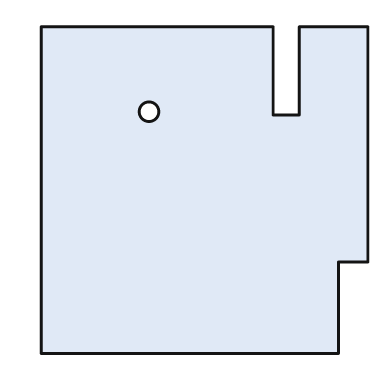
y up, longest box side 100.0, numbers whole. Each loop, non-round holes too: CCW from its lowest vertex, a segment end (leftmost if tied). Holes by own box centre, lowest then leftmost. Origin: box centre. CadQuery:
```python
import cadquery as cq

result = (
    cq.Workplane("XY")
    .moveTo(-50.0, -50.0)
    .lineTo(41.0, -50.0)
    .lineTo(41.0, -22.0)
    .lineTo(50.0, -22.0)
    .lineTo(50.0, 50.0)
    .lineTo(29.0, 50.0)
    .lineTo(29.0, 23.0)
    .lineTo(21.0, 23.0)
    .lineTo(21.0, 50.0)
    .lineTo(-50.0, 50.0)
    .close()
    .moveTo(-17.0, 24.0)
    .circle(3.0)
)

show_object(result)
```